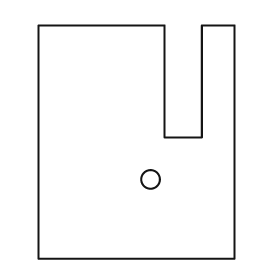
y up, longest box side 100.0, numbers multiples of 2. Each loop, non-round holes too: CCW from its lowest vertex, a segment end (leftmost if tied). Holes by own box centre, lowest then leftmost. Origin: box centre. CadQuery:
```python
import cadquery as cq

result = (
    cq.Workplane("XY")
    .moveTo(-42.0, -50.0)
    .lineTo(42.0, -50.0)
    .lineTo(42.0, 50.0)
    .lineTo(28.0, 50.0)
    .lineTo(28.0, 2.0)
    .lineTo(12.0, 2.0)
    .lineTo(12.0, 50.0)
    .lineTo(-42.0, 50.0)
    .close()
    .moveTo(6.0, -16.0)
    .circle(4.0)
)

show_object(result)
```